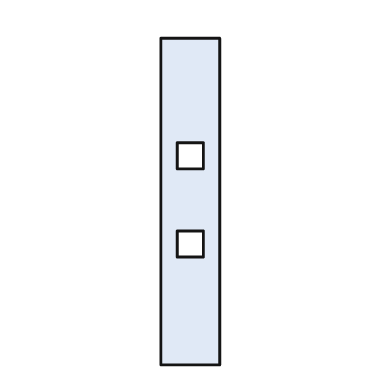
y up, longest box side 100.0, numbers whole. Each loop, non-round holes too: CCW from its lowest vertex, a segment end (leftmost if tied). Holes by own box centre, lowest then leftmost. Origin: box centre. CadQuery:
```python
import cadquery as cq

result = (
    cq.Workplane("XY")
    .moveTo(-9.0, -50.0)
    .lineTo(9.0, -50.0)
    .lineTo(9.0, 50.0)
    .lineTo(-9.0, 50.0)
    .close()
    .moveTo(-4.0, -17.0)
    .lineTo(4.0, -17.0)
    .lineTo(4.0, -9.0)
    .lineTo(-4.0, -9.0)
    .close()
    .moveTo(-4.0, 10.0)
    .lineTo(4.0, 10.0)
    .lineTo(4.0, 18.0)
    .lineTo(-4.0, 18.0)
    .close()
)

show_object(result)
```